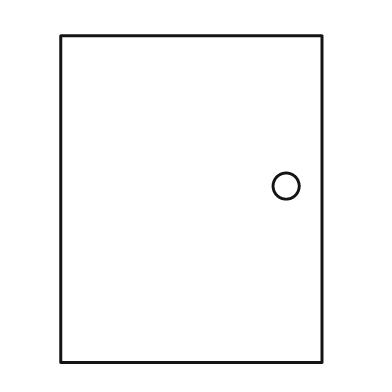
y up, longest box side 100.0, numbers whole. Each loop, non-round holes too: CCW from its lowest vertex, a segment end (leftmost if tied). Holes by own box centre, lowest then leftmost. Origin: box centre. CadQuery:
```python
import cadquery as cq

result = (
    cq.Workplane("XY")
    .moveTo(-40.0, -50.0)
    .lineTo(40.0, -50.0)
    .lineTo(40.0, 50.0)
    .lineTo(-40.0, 50.0)
    .close()
    .moveTo(29.0, 4.0)
    .circle(4.0)
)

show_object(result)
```